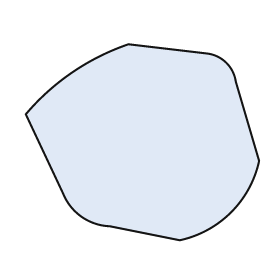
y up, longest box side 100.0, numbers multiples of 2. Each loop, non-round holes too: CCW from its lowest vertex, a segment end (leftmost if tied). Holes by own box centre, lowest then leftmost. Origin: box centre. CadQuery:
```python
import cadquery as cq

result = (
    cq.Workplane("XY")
    .moveTo(16.0, -42.0)
    .threePointArc((38.0, -30.0), (50.0, -8.0))
    .lineTo(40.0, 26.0)
    .threePointArc((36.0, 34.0), (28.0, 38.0))
    .lineTo(-6.0, 42.0)
    .threePointArc((-30.0, 30.0), (-50.0, 12.0))
    .lineTo(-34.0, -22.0)
    .threePointArc((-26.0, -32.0), (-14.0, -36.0))
    .close()
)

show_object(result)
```